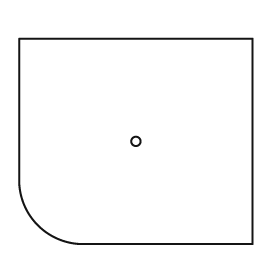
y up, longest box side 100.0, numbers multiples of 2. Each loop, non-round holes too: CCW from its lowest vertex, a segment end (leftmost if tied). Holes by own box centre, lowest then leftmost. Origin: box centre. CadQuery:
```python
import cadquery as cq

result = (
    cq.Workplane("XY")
    .moveTo(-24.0, -44.0)
    .lineTo(50.0, -44.0)
    .lineTo(50.0, 44.0)
    .lineTo(-50.0, 44.0)
    .lineTo(-50.0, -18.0)
    .threePointArc((-42.0, -36.0), (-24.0, -44.0))
    .close()
    .moveTo(0.0, 0.0)
    .circle(2.0)
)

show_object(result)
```